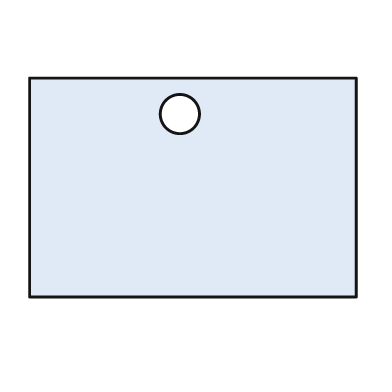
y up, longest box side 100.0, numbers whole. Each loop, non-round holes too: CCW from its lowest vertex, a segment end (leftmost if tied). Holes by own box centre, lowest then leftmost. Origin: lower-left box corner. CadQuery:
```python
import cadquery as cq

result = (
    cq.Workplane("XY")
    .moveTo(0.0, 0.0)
    .lineTo(100.0, 0.0)
    .lineTo(100.0, 67.0)
    .lineTo(0.0, 67.0)
    .close()
    .moveTo(46.0, 56.0)
    .circle(6.0)
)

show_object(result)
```